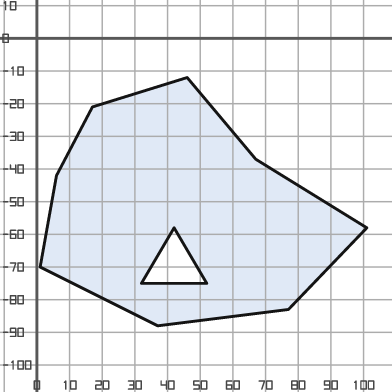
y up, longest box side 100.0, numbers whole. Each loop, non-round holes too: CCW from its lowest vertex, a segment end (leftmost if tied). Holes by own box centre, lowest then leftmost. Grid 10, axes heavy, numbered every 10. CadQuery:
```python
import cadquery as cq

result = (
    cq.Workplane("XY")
    .moveTo(37.0, -88.0)
    .lineTo(77.0, -83.0)
    .lineTo(101.0, -58.0)
    .lineTo(67.0, -37.0)
    .lineTo(46.0, -12.0)
    .lineTo(17.0, -21.0)
    .lineTo(6.0, -42.0)
    .lineTo(1.0, -70.0)
    .close()
    .moveTo(32.0, -75.0)
    .lineTo(52.0, -75.0)
    .lineTo(42.0, -58.0)
    .close()
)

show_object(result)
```